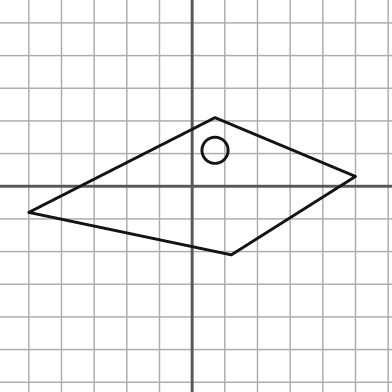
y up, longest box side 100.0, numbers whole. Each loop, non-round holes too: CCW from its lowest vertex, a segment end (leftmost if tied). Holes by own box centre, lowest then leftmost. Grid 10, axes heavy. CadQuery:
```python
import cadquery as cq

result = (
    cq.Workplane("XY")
    .moveTo(12.0, -21.0)
    .lineTo(50.0, 3.0)
    .lineTo(7.0, 21.0)
    .lineTo(-50.0, -8.0)
    .close()
    .moveTo(7.0, 11.0)
    .circle(4.0)
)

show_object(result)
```